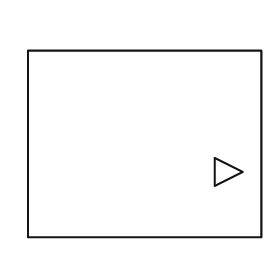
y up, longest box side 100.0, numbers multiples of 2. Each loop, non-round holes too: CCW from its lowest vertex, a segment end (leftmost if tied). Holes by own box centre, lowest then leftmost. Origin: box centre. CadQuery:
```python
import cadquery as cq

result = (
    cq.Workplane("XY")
    .moveTo(-50.0, -40.0)
    .lineTo(50.0, -40.0)
    .lineTo(50.0, 40.0)
    .lineTo(-50.0, 40.0)
    .close()
    .moveTo(30.0, -18.0)
    .lineTo(42.0, -12.0)
    .lineTo(30.0, -6.0)
    .close()
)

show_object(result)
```